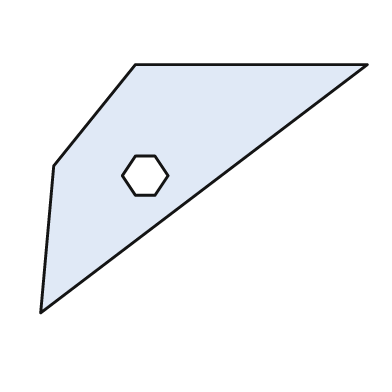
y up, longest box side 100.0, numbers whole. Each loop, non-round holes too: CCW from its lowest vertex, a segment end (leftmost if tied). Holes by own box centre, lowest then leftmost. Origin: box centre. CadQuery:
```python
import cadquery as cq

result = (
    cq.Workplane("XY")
    .moveTo(-50.0, -38.0)
    .lineTo(50.0, 38.0)
    .lineTo(-21.0, 38.0)
    .lineTo(-46.0, 7.0)
    .close()
    .moveTo(-21.0, -2.0)
    .lineTo(-15.0, -2.0)
    .lineTo(-11.0, 4.0)
    .lineTo(-15.0, 10.0)
    .lineTo(-21.0, 10.0)
    .lineTo(-25.0, 4.0)
    .close()
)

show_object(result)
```